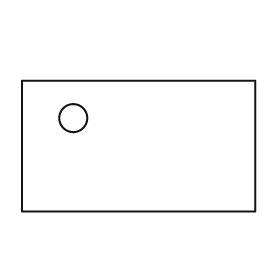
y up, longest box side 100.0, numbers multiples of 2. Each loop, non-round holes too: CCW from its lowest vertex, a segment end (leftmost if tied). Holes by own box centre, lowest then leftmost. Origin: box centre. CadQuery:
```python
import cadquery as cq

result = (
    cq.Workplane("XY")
    .moveTo(-50.0, -28.0)
    .lineTo(50.0, -28.0)
    .lineTo(50.0, 28.0)
    .lineTo(-50.0, 28.0)
    .close()
    .moveTo(-28.0, 12.0)
    .circle(6.0)
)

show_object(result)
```